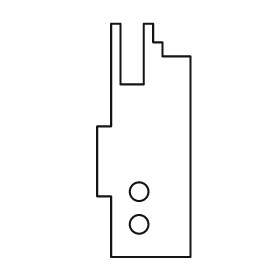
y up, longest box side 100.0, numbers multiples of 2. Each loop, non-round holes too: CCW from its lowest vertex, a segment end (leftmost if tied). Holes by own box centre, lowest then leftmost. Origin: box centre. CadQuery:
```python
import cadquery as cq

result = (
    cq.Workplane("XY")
    .moveTo(-14.0, -50.0)
    .lineTo(20.0, -50.0)
    .lineTo(20.0, 36.0)
    .lineTo(8.0, 36.0)
    .lineTo(8.0, 42.0)
    .lineTo(4.0, 42.0)
    .lineTo(4.0, 50.0)
    .lineTo(0.0, 50.0)
    .lineTo(0.0, 24.0)
    .lineTo(-10.0, 24.0)
    .lineTo(-10.0, 50.0)
    .lineTo(-14.0, 50.0)
    .lineTo(-14.0, 6.0)
    .lineTo(-20.0, 6.0)
    .lineTo(-20.0, -24.0)
    .lineTo(-14.0, -24.0)
    .close()
    .moveTo(-2.0, -36.0)
    .circle(4.0)
    .moveTo(-2.0, -22.0)
    .circle(4.0)
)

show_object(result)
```